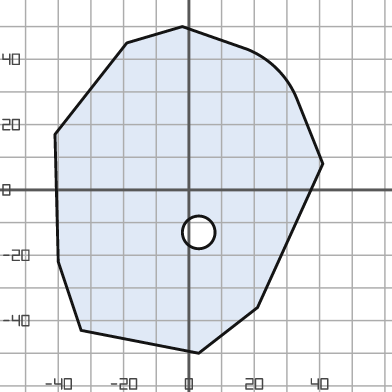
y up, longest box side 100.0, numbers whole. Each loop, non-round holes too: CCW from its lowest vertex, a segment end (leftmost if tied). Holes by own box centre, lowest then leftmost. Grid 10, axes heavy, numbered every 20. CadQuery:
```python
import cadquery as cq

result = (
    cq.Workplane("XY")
    .moveTo(3.0, -50.0)
    .lineTo(21.0, -36.0)
    .lineTo(41.0, 8.0)
    .lineTo(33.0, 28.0)
    .threePointArc((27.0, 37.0), (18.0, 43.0))
    .lineTo(-2.0, 50.0)
    .lineTo(-19.0, 45.0)
    .lineTo(-41.0, 17.0)
    .lineTo(-40.0, -22.0)
    .lineTo(-33.0, -43.0)
    .close()
    .moveTo(3.0, -13.0)
    .circle(5.0)
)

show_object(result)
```